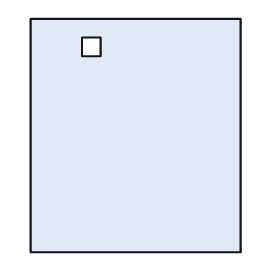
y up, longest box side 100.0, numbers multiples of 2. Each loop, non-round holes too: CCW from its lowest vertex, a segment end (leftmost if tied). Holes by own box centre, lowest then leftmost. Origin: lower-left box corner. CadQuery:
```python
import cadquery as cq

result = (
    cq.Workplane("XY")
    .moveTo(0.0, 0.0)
    .lineTo(90.0, 0.0)
    .lineTo(90.0, 100.0)
    .lineTo(0.0, 100.0)
    .close()
    .moveTo(22.0, 84.0)
    .lineTo(30.0, 84.0)
    .lineTo(30.0, 92.0)
    .lineTo(22.0, 92.0)
    .close()
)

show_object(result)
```